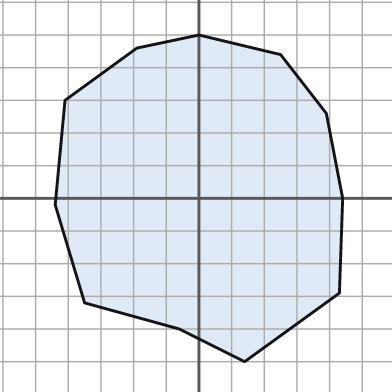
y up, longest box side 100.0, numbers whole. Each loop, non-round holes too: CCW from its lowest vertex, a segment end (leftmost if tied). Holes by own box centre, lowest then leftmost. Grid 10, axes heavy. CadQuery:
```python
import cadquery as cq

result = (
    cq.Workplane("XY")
    .moveTo(14.0, -50.0)
    .lineTo(43.0, -29.0)
    .lineTo(44.0, 0.0)
    .lineTo(39.0, 26.0)
    .lineTo(25.0, 44.0)
    .lineTo(0.0, 50.0)
    .lineTo(-19.0, 46.0)
    .lineTo(-41.0, 30.0)
    .lineTo(-44.0, -2.0)
    .lineTo(-35.0, -32.0)
    .lineTo(-6.0, -40.0)
    .close()
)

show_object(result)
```